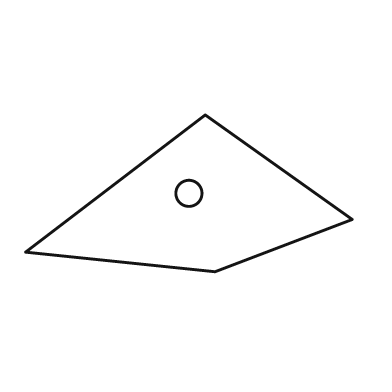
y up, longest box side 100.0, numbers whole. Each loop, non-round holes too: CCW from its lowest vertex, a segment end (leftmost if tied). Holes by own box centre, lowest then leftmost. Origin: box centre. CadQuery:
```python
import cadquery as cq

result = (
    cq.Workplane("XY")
    .moveTo(8.0, -24.0)
    .lineTo(50.0, -8.0)
    .lineTo(5.0, 24.0)
    .lineTo(-50.0, -18.0)
    .close()
    .moveTo(0.0, 0.0)
    .circle(4.0)
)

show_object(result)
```